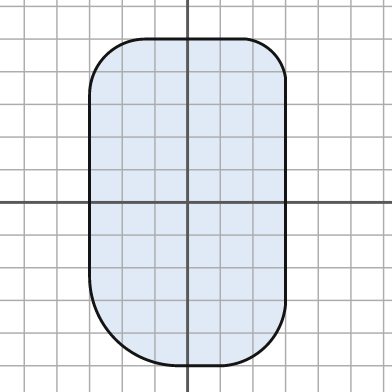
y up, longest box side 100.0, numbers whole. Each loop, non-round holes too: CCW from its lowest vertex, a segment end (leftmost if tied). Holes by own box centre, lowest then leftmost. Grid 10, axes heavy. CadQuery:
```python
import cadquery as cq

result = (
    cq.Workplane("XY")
    .moveTo(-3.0, -50.0)
    .lineTo(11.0, -50.0)
    .threePointArc((24.0, -44.0), (30.0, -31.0))
    .lineTo(30.0, 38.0)
    .threePointArc((26.0, 46.0), (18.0, 50.0))
    .lineTo(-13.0, 50.0)
    .threePointArc((-25.0, 45.0), (-30.0, 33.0))
    .lineTo(-30.0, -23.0)
    .threePointArc((-22.0, -42.0), (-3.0, -50.0))
    .close()
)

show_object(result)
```